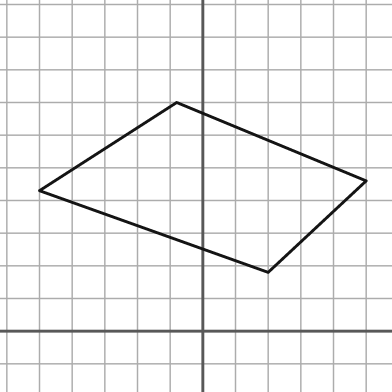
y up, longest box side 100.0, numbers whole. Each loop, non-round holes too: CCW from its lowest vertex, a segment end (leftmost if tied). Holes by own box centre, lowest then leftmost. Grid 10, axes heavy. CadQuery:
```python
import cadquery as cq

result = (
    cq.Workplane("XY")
    .moveTo(20.0, 18.0)
    .lineTo(50.0, 46.0)
    .lineTo(-8.0, 70.0)
    .lineTo(-50.0, 43.0)
    .close()
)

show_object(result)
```